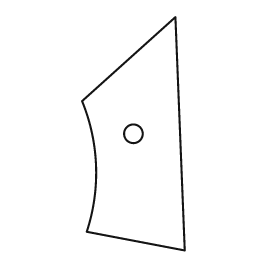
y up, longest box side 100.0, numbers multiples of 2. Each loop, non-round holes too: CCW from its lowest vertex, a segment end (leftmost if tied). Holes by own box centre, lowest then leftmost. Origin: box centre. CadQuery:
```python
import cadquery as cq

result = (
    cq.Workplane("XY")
    .moveTo(22.0, -50.0)
    .lineTo(18.0, 50.0)
    .lineTo(-22.0, 14.0)
    .threePointArc((-16.0, -14.0), (-20.0, -42.0))
    .close()
    .moveTo(0.0, 0.0)
    .circle(4.0)
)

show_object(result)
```